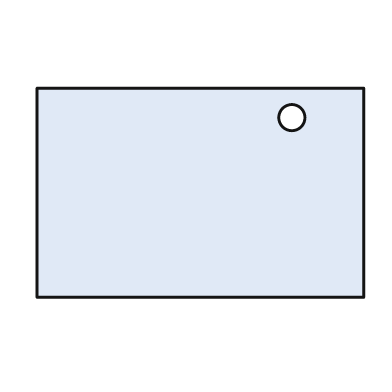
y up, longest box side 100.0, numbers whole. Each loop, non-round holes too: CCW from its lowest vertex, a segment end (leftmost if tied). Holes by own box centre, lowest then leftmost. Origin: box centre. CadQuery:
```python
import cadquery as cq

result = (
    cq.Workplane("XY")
    .moveTo(-50.0, -32.0)
    .lineTo(50.0, -32.0)
    .lineTo(50.0, 32.0)
    .lineTo(-50.0, 32.0)
    .close()
    .moveTo(28.0, 23.0)
    .circle(4.0)
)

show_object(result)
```